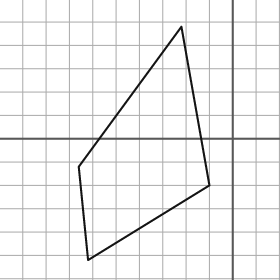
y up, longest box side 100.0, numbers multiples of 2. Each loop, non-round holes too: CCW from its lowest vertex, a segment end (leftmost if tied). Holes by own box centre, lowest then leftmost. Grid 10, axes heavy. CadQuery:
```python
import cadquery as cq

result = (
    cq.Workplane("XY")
    .moveTo(-62.0, -52.0)
    .lineTo(-10.0, -20.0)
    .lineTo(-22.0, 48.0)
    .lineTo(-66.0, -12.0)
    .close()
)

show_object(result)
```